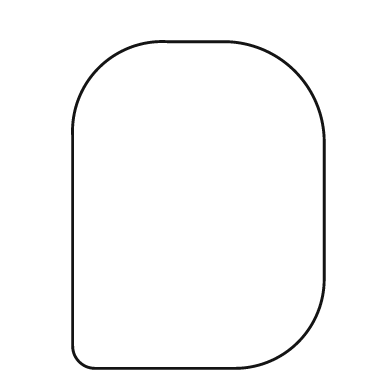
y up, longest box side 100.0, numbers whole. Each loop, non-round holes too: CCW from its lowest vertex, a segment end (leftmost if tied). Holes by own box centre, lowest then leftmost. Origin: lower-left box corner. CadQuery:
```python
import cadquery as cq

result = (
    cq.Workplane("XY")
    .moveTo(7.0, 0.0)
    .lineTo(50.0, 0.0)
    .threePointArc((69.0, 8.0), (77.0, 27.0))
    .lineTo(77.0, 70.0)
    .threePointArc((68.0, 91.0), (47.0, 100.0))
    .lineTo(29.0, 100.0)
    .threePointArc((8.0, 92.0), (0.0, 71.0))
    .lineTo(0.0, 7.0)
    .threePointArc((2.0, 2.0), (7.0, 0.0))
    .close()
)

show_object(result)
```